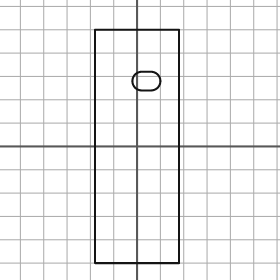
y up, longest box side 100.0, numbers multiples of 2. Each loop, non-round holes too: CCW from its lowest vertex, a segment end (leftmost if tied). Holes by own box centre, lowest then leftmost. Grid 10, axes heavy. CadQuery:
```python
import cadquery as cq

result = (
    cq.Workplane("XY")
    .moveTo(-18.0, -50.0)
    .lineTo(18.0, -50.0)
    .lineTo(18.0, 50.0)
    .lineTo(-18.0, 50.0)
    .close()
    .moveTo(2.0, 24.0)
    .lineTo(6.0, 24.0)
    .threePointArc((10.0, 28.0), (6.0, 32.0))
    .lineTo(2.0, 32.0)
    .threePointArc((-2.0, 28.0), (2.0, 24.0))
    .close()
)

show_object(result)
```